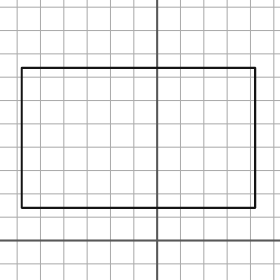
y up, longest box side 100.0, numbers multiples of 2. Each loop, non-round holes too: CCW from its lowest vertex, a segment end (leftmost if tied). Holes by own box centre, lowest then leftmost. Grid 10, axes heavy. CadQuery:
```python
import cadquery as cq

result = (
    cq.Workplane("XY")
    .moveTo(-58.0, 14.0)
    .lineTo(42.0, 14.0)
    .lineTo(42.0, 74.0)
    .lineTo(-58.0, 74.0)
    .close()
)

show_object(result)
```